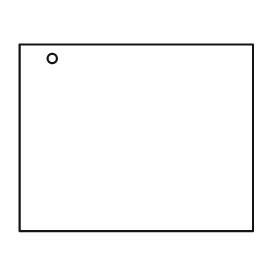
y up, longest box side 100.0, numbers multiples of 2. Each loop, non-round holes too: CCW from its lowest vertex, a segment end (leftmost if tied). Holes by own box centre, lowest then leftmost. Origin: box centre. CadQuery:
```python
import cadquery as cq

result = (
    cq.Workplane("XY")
    .moveTo(-50.0, -40.0)
    .lineTo(50.0, -40.0)
    .lineTo(50.0, 40.0)
    .lineTo(-50.0, 40.0)
    .close()
    .moveTo(-36.0, 34.0)
    .circle(2.0)
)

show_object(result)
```